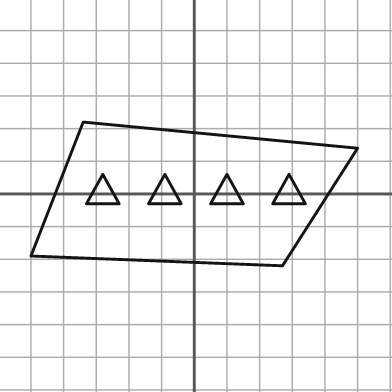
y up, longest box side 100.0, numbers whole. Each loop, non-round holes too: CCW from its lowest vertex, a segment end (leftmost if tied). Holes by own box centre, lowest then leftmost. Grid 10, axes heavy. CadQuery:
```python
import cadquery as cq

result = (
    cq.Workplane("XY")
    .moveTo(27.0, -22.0)
    .lineTo(50.0, 14.0)
    .lineTo(-34.0, 22.0)
    .lineTo(-50.0, -19.0)
    .close()
    .moveTo(-33.0, -3.0)
    .lineTo(-23.0, -3.0)
    .lineTo(-28.0, 6.0)
    .close()
    .moveTo(-14.0, -3.0)
    .lineTo(-4.0, -3.0)
    .lineTo(-9.0, 6.0)
    .close()
    .moveTo(5.0, -3.0)
    .lineTo(15.0, -3.0)
    .lineTo(10.0, 6.0)
    .close()
    .moveTo(24.0, -3.0)
    .lineTo(34.0, -3.0)
    .lineTo(29.0, 6.0)
    .close()
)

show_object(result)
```